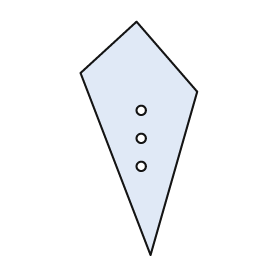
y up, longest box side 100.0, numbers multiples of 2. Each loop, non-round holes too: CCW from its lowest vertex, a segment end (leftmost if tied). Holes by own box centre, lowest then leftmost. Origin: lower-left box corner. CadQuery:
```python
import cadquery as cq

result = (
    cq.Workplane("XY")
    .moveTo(30.0, 0.0)
    .lineTo(50.0, 70.0)
    .lineTo(24.0, 100.0)
    .lineTo(0.0, 78.0)
    .close()
    .moveTo(26.0, 38.0)
    .circle(2.0)
    .moveTo(26.0, 50.0)
    .circle(2.0)
    .moveTo(26.0, 62.0)
    .circle(2.0)
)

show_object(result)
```